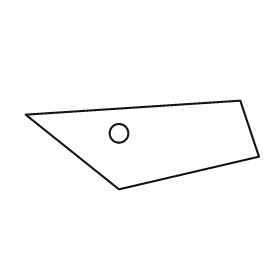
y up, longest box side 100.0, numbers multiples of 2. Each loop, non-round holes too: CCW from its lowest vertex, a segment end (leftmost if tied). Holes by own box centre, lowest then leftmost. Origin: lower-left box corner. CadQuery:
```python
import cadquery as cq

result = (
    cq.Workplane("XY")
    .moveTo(40.0, 0.0)
    .lineTo(100.0, 14.0)
    .lineTo(92.0, 38.0)
    .lineTo(0.0, 32.0)
    .close()
    .moveTo(40.0, 24.0)
    .circle(4.0)
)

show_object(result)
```